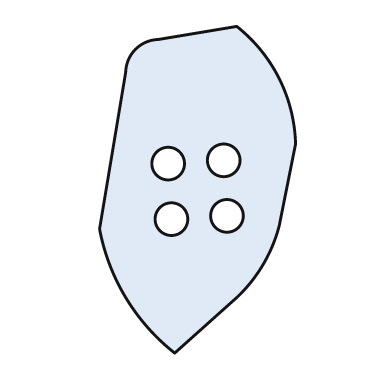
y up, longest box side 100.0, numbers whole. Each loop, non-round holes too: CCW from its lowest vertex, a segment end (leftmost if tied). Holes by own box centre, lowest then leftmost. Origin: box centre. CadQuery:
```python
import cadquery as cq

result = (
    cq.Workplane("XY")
    .moveTo(-7.0, -50.0)
    .lineTo(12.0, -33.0)
    .threePointArc((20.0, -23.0), (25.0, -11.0))
    .lineTo(30.0, 14.0)
    .threePointArc((25.0, 34.0), (12.0, 50.0))
    .lineTo(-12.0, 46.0)
    .threePointArc((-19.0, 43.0), (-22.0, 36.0))
    .lineTo(-30.0, -12.0)
    .threePointArc((-22.0, -33.0), (-7.0, -50.0))
    .close()
    .moveTo(-8.0, -9.0)
    .circle(5.0)
    .moveTo(9.0, -8.0)
    .circle(5.0)
    .moveTo(-9.0, 8.0)
    .circle(5.0)
    .moveTo(8.0, 9.0)
    .circle(5.0)
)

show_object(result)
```